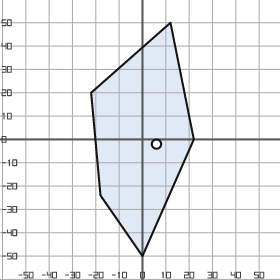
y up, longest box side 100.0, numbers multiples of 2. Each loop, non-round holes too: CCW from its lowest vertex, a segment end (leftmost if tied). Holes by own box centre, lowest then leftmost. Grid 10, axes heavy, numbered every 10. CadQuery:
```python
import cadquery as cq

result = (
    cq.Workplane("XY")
    .moveTo(0.0, -50.0)
    .lineTo(22.0, 0.0)
    .lineTo(12.0, 50.0)
    .lineTo(-22.0, 20.0)
    .lineTo(-18.0, -24.0)
    .close()
    .moveTo(6.0, -2.0)
    .circle(2.0)
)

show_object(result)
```